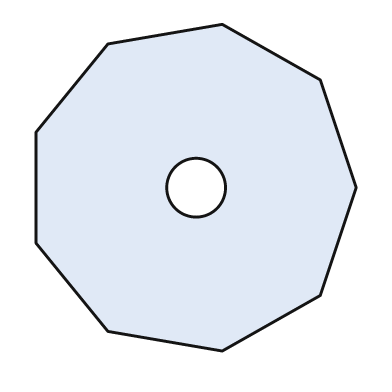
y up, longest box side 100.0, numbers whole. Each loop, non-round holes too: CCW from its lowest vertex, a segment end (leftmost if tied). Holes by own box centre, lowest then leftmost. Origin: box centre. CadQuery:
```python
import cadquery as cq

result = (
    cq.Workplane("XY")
    .moveTo(8.0, -50.0)
    .lineTo(38.0, -33.0)
    .lineTo(49.0, 0.0)
    .lineTo(38.0, 33.0)
    .lineTo(8.0, 50.0)
    .lineTo(-27.0, 44.0)
    .lineTo(-49.0, 17.0)
    .lineTo(-49.0, -17.0)
    .lineTo(-27.0, -44.0)
    .close()
    .moveTo(0.0, 0.0)
    .circle(9.0)
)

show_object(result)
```